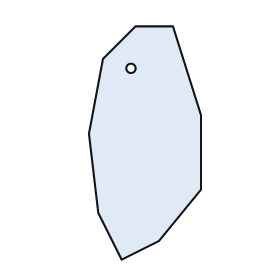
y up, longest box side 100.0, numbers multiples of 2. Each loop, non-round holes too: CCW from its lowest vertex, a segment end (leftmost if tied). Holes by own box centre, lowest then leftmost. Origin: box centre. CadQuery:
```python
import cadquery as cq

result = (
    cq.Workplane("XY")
    .moveTo(-10.0, -50.0)
    .lineTo(6.0, -42.0)
    .lineTo(24.0, -20.0)
    .lineTo(24.0, 12.0)
    .lineTo(12.0, 50.0)
    .lineTo(-4.0, 50.0)
    .lineTo(-18.0, 36.0)
    .lineTo(-24.0, 4.0)
    .lineTo(-20.0, -30.0)
    .close()
    .moveTo(-6.0, 32.0)
    .circle(2.0)
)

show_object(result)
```